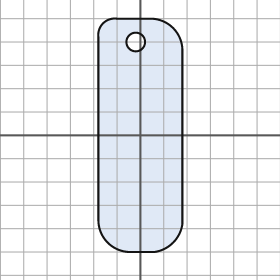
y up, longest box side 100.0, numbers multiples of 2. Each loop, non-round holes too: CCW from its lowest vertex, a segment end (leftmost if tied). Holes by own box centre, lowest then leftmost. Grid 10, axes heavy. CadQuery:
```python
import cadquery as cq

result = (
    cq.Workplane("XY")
    .moveTo(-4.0, -50.0)
    .lineTo(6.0, -50.0)
    .threePointArc((14.0, -46.0), (18.0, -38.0))
    .lineTo(18.0, 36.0)
    .threePointArc((14.0, 46.0), (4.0, 50.0))
    .lineTo(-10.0, 50.0)
    .threePointArc((-16.0, 48.0), (-18.0, 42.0))
    .lineTo(-18.0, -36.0)
    .threePointArc((-14.0, -46.0), (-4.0, -50.0))
    .close()
    .moveTo(-2.0, 40.0)
    .circle(4.0)
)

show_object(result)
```